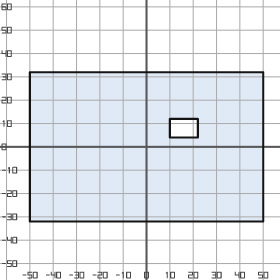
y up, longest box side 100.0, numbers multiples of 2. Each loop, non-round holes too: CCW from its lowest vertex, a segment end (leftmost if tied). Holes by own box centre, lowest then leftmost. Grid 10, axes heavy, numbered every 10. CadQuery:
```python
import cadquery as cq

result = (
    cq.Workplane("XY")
    .moveTo(-50.0, -32.0)
    .lineTo(50.0, -32.0)
    .lineTo(50.0, 32.0)
    .lineTo(-50.0, 32.0)
    .close()
    .moveTo(10.0, 4.0)
    .lineTo(22.0, 4.0)
    .lineTo(22.0, 12.0)
    .lineTo(10.0, 12.0)
    .close()
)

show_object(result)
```